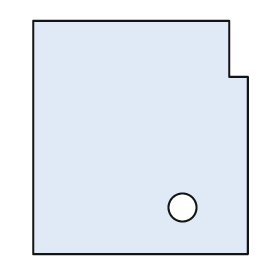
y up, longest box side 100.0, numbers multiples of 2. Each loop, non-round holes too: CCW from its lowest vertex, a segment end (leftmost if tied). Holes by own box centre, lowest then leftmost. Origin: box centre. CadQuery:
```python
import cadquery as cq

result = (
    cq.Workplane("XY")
    .moveTo(-46.0, -50.0)
    .lineTo(46.0, -50.0)
    .lineTo(46.0, 26.0)
    .lineTo(38.0, 26.0)
    .lineTo(38.0, 50.0)
    .lineTo(-46.0, 50.0)
    .close()
    .moveTo(18.0, -30.0)
    .circle(6.0)
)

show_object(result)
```